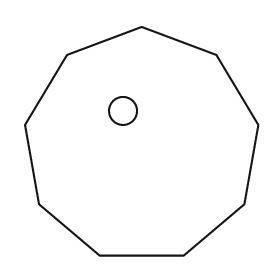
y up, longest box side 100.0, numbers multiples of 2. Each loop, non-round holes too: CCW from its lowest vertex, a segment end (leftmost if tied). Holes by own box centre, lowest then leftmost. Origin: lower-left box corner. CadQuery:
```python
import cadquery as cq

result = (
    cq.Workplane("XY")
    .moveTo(32.0, 0.0)
    .lineTo(68.0, 0.0)
    .lineTo(94.0, 22.0)
    .lineTo(100.0, 56.0)
    .lineTo(82.0, 86.0)
    .lineTo(50.0, 98.0)
    .lineTo(18.0, 86.0)
    .lineTo(0.0, 56.0)
    .lineTo(6.0, 22.0)
    .close()
    .moveTo(42.0, 62.0)
    .circle(6.0)
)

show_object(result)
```